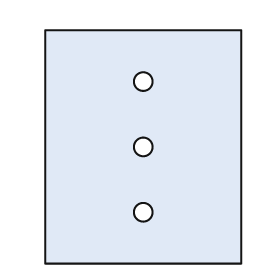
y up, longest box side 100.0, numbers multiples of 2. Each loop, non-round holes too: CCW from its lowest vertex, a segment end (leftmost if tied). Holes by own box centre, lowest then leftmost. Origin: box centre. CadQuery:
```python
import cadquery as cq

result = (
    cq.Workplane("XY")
    .moveTo(-42.0, -50.0)
    .lineTo(42.0, -50.0)
    .lineTo(42.0, 50.0)
    .lineTo(-42.0, 50.0)
    .close()
    .moveTo(0.0, -28.0)
    .circle(4.0)
    .moveTo(0.0, 0.0)
    .circle(4.0)
    .moveTo(0.0, 28.0)
    .circle(4.0)
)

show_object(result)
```